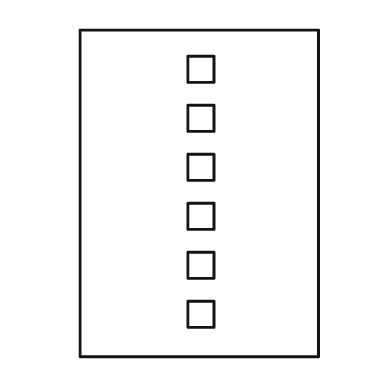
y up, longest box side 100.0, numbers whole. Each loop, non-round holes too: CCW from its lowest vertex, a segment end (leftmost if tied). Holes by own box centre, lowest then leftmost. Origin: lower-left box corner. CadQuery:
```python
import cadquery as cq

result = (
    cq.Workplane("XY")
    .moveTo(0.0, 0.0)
    .lineTo(73.0, 0.0)
    .lineTo(73.0, 100.0)
    .lineTo(0.0, 100.0)
    .close()
    .moveTo(33.0, 9.0)
    .lineTo(41.0, 9.0)
    .lineTo(41.0, 17.0)
    .lineTo(33.0, 17.0)
    .close()
    .moveTo(33.0, 24.0)
    .lineTo(41.0, 24.0)
    .lineTo(41.0, 32.0)
    .lineTo(33.0, 32.0)
    .close()
    .moveTo(33.0, 39.0)
    .lineTo(41.0, 39.0)
    .lineTo(41.0, 47.0)
    .lineTo(33.0, 47.0)
    .close()
    .moveTo(33.0, 54.0)
    .lineTo(41.0, 54.0)
    .lineTo(41.0, 62.0)
    .lineTo(33.0, 62.0)
    .close()
    .moveTo(33.0, 69.0)
    .lineTo(41.0, 69.0)
    .lineTo(41.0, 77.0)
    .lineTo(33.0, 77.0)
    .close()
    .moveTo(33.0, 84.0)
    .lineTo(41.0, 84.0)
    .lineTo(41.0, 92.0)
    .lineTo(33.0, 92.0)
    .close()
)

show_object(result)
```